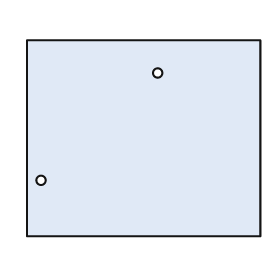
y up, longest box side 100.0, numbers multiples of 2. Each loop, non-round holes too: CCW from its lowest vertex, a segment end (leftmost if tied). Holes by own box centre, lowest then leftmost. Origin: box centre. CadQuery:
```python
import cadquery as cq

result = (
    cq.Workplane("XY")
    .moveTo(-50.0, -42.0)
    .lineTo(50.0, -42.0)
    .lineTo(50.0, 42.0)
    .lineTo(-50.0, 42.0)
    .close()
    .moveTo(-44.0, -18.0)
    .circle(2.0)
    .moveTo(6.0, 28.0)
    .circle(2.0)
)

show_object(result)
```